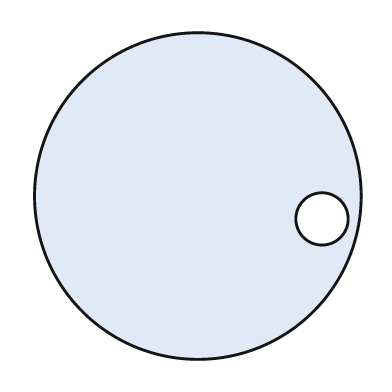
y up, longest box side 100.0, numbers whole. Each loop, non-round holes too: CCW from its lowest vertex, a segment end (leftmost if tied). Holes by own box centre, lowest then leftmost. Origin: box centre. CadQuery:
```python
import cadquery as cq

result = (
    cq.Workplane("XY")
    .moveTo(0.0, 0.0)
    .circle(50.0)
    .moveTo(38.0, -7.0)
    .circle(8.0)
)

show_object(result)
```